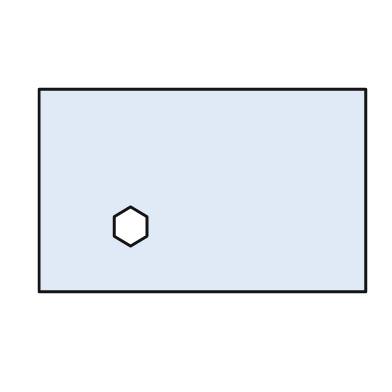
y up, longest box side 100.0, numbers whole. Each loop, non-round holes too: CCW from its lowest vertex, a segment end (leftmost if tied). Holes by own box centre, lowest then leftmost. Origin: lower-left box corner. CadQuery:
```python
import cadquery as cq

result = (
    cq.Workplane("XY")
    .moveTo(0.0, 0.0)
    .lineTo(100.0, 0.0)
    .lineTo(100.0, 62.0)
    .lineTo(0.0, 62.0)
    .close()
    .moveTo(28.0, 14.0)
    .lineTo(33.0, 17.0)
    .lineTo(33.0, 23.0)
    .lineTo(28.0, 26.0)
    .lineTo(23.0, 23.0)
    .lineTo(23.0, 17.0)
    .close()
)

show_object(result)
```